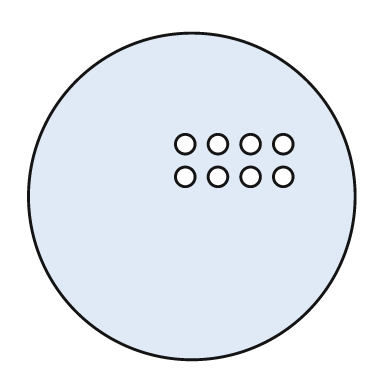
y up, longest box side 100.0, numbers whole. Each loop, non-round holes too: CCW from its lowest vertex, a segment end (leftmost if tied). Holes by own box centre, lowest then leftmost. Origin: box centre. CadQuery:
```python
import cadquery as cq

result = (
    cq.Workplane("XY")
    .moveTo(0.0, 0.0)
    .circle(50.0)
    .moveTo(-2.0, 6.0)
    .circle(3.0)
    .moveTo(8.0, 6.0)
    .circle(3.0)
    .moveTo(18.0, 6.0)
    .circle(3.0)
    .moveTo(28.0, 6.0)
    .circle(3.0)
    .moveTo(-2.0, 16.0)
    .circle(3.0)
    .moveTo(8.0, 16.0)
    .circle(3.0)
    .moveTo(18.0, 16.0)
    .circle(3.0)
    .moveTo(28.0, 16.0)
    .circle(3.0)
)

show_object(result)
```